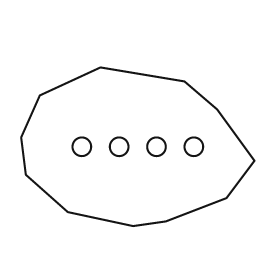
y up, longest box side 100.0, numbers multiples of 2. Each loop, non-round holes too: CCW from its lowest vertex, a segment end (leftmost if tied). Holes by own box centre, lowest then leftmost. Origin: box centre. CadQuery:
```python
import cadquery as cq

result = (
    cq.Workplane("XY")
    .moveTo(-2.0, -34.0)
    .lineTo(12.0, -32.0)
    .lineTo(38.0, -22.0)
    .lineTo(50.0, -6.0)
    .lineTo(34.0, 16.0)
    .lineTo(20.0, 28.0)
    .lineTo(-16.0, 34.0)
    .lineTo(-42.0, 22.0)
    .lineTo(-50.0, 4.0)
    .lineTo(-48.0, -12.0)
    .lineTo(-30.0, -28.0)
    .close()
    .moveTo(-24.0, 0.0)
    .circle(4.0)
    .moveTo(-8.0, 0.0)
    .circle(4.0)
    .moveTo(8.0, 0.0)
    .circle(4.0)
    .moveTo(24.0, 0.0)
    .circle(4.0)
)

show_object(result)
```